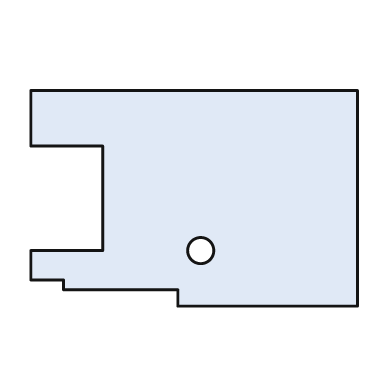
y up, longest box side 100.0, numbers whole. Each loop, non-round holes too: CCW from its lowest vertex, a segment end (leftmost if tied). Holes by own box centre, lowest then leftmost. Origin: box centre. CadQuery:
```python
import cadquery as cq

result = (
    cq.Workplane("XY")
    .moveTo(-5.0, -33.0)
    .lineTo(50.0, -33.0)
    .lineTo(50.0, 33.0)
    .lineTo(-50.0, 33.0)
    .lineTo(-50.0, 16.0)
    .lineTo(-28.0, 16.0)
    .lineTo(-28.0, -16.0)
    .lineTo(-50.0, -16.0)
    .lineTo(-50.0, -25.0)
    .lineTo(-40.0, -25.0)
    .lineTo(-40.0, -28.0)
    .lineTo(-5.0, -28.0)
    .close()
    .moveTo(2.0, -16.0)
    .circle(4.0)
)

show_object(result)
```